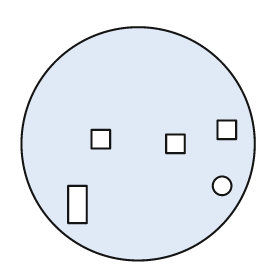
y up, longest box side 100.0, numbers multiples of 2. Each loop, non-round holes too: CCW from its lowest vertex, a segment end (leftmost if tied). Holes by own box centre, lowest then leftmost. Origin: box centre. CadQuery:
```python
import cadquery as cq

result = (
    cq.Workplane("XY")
    .moveTo(0.0, 0.0)
    .circle(50.0)
    .moveTo(-30.0, -34.0)
    .lineTo(-22.0, -34.0)
    .lineTo(-22.0, -18.0)
    .lineTo(-30.0, -18.0)
    .close()
    .moveTo(36.0, -18.0)
    .circle(4.0)
    .moveTo(12.0, -4.0)
    .lineTo(20.0, -4.0)
    .lineTo(20.0, 4.0)
    .lineTo(12.0, 4.0)
    .close()
    .moveTo(-20.0, -2.0)
    .lineTo(-12.0, -2.0)
    .lineTo(-12.0, 6.0)
    .lineTo(-20.0, 6.0)
    .close()
    .moveTo(34.0, 2.0)
    .lineTo(42.0, 2.0)
    .lineTo(42.0, 10.0)
    .lineTo(34.0, 10.0)
    .close()
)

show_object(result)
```